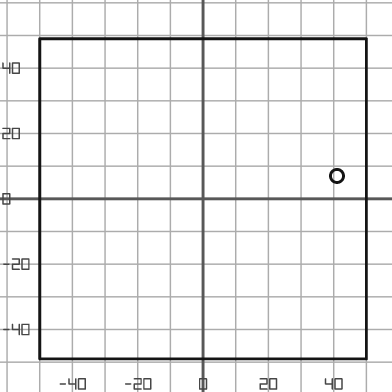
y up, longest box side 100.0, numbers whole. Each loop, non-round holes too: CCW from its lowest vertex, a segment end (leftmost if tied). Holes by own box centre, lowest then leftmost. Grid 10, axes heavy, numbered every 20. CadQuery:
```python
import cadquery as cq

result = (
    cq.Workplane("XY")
    .moveTo(-50.0, -49.0)
    .lineTo(50.0, -49.0)
    .lineTo(50.0, 49.0)
    .lineTo(-50.0, 49.0)
    .close()
    .moveTo(41.0, 7.0)
    .circle(2.0)
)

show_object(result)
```